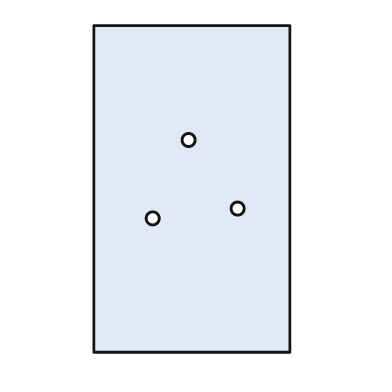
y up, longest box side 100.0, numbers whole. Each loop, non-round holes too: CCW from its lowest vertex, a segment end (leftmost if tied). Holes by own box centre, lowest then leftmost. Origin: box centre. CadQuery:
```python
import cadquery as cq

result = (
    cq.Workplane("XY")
    .moveTo(-30.0, -50.0)
    .lineTo(30.0, -50.0)
    .lineTo(30.0, 50.0)
    .lineTo(-30.0, 50.0)
    .close()
    .moveTo(-12.0, -9.0)
    .circle(2.0)
    .moveTo(14.0, -6.0)
    .circle(2.0)
    .moveTo(-1.0, 15.0)
    .circle(2.0)
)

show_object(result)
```